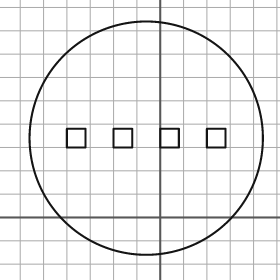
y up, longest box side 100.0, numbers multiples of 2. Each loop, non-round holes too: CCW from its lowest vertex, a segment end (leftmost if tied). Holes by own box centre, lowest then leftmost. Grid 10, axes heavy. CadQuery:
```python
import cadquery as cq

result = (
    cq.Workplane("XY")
    .moveTo(-6.0, 34.0)
    .circle(50.0)
    .moveTo(-40.0, 30.0)
    .lineTo(-32.0, 30.0)
    .lineTo(-32.0, 38.0)
    .lineTo(-40.0, 38.0)
    .close()
    .moveTo(-20.0, 30.0)
    .lineTo(-12.0, 30.0)
    .lineTo(-12.0, 38.0)
    .lineTo(-20.0, 38.0)
    .close()
    .moveTo(0.0, 30.0)
    .lineTo(8.0, 30.0)
    .lineTo(8.0, 38.0)
    .lineTo(0.0, 38.0)
    .close()
    .moveTo(20.0, 30.0)
    .lineTo(28.0, 30.0)
    .lineTo(28.0, 38.0)
    .lineTo(20.0, 38.0)
    .close()
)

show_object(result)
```